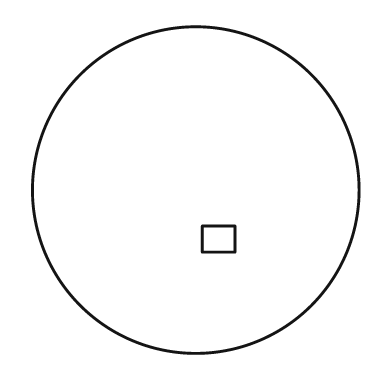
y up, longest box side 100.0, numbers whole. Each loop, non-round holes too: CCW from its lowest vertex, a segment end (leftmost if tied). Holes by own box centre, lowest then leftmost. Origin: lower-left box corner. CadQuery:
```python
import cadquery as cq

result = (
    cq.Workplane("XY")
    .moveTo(50.0, 50.0)
    .circle(50.0)
    .moveTo(52.0, 31.0)
    .lineTo(62.0, 31.0)
    .lineTo(62.0, 39.0)
    .lineTo(52.0, 39.0)
    .close()
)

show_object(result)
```